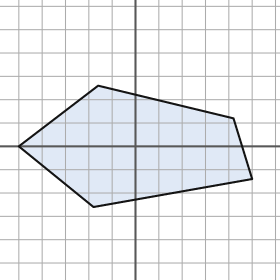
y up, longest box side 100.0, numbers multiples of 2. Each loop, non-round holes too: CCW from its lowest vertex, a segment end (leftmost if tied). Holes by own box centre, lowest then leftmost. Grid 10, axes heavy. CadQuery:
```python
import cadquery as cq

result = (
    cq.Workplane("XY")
    .moveTo(-18.0, -26.0)
    .lineTo(50.0, -14.0)
    .lineTo(42.0, 12.0)
    .lineTo(-16.0, 26.0)
    .lineTo(-50.0, 0.0)
    .close()
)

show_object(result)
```